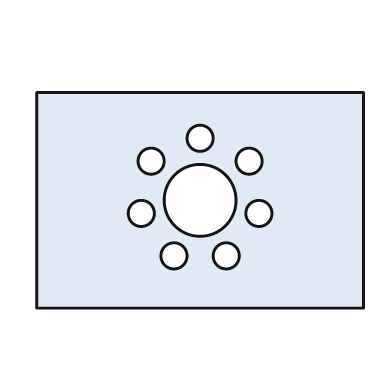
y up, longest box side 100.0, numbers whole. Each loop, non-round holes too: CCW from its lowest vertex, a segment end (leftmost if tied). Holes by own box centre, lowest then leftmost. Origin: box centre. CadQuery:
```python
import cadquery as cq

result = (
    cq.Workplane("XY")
    .moveTo(-50.0, -33.0)
    .lineTo(50.0, -33.0)
    .lineTo(50.0, 33.0)
    .lineTo(-50.0, 33.0)
    .close()
    .moveTo(-8.0, -17.0)
    .circle(4.0)
    .moveTo(8.0, -17.0)
    .circle(4.0)
    .moveTo(-18.0, -4.0)
    .circle(4.0)
    .moveTo(18.0, -4.0)
    .circle(4.0)
    .moveTo(0.0, 0.0)
    .circle(11.0)
    .moveTo(-15.0, 12.0)
    .circle(4.0)
    .moveTo(15.0, 12.0)
    .circle(4.0)
    .moveTo(0.0, 19.0)
    .circle(4.0)
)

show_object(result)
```